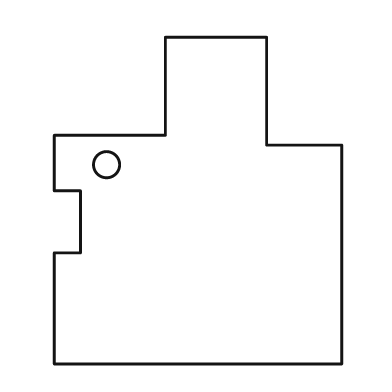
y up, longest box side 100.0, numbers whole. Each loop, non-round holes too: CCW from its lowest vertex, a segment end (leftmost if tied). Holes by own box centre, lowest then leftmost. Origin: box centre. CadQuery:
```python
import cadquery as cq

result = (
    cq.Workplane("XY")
    .moveTo(-44.0, -50.0)
    .lineTo(44.0, -50.0)
    .lineTo(44.0, 17.0)
    .lineTo(21.0, 17.0)
    .lineTo(21.0, 50.0)
    .lineTo(-10.0, 50.0)
    .lineTo(-10.0, 20.0)
    .lineTo(-44.0, 20.0)
    .lineTo(-44.0, 3.0)
    .lineTo(-36.0, 3.0)
    .lineTo(-36.0, -16.0)
    .lineTo(-44.0, -16.0)
    .close()
    .moveTo(-28.0, 11.0)
    .circle(4.0)
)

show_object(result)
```